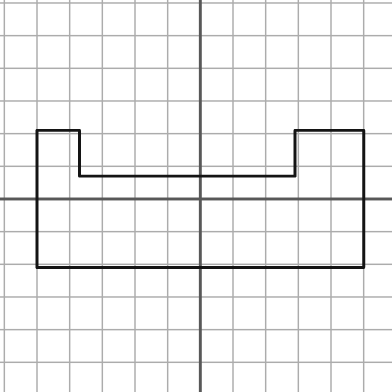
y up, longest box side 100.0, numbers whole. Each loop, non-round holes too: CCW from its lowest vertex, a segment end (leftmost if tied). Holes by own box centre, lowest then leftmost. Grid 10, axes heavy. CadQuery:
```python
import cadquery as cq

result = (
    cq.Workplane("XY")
    .moveTo(-50.0, -21.0)
    .lineTo(50.0, -21.0)
    .lineTo(50.0, 21.0)
    .lineTo(29.0, 21.0)
    .lineTo(29.0, 7.0)
    .lineTo(-37.0, 7.0)
    .lineTo(-37.0, 21.0)
    .lineTo(-50.0, 21.0)
    .close()
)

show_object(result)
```